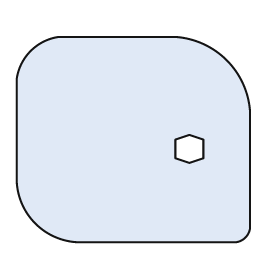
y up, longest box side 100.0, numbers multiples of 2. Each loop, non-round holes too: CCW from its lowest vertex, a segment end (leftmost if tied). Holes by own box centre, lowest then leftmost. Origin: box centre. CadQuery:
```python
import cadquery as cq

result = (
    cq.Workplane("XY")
    .moveTo(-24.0, -44.0)
    .lineTo(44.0, -44.0)
    .threePointArc((48.0, -42.0), (50.0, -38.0))
    .lineTo(50.0, 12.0)
    .threePointArc((40.0, 34.0), (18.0, 44.0))
    .lineTo(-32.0, 44.0)
    .threePointArc((-44.0, 38.0), (-50.0, 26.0))
    .lineTo(-50.0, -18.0)
    .threePointArc((-42.0, -36.0), (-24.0, -44.0))
    .close()
    .moveTo(24.0, -10.0)
    .lineTo(30.0, -8.0)
    .lineTo(30.0, 0.0)
    .lineTo(24.0, 2.0)
    .lineTo(18.0, 0.0)
    .lineTo(18.0, -8.0)
    .close()
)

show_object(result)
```